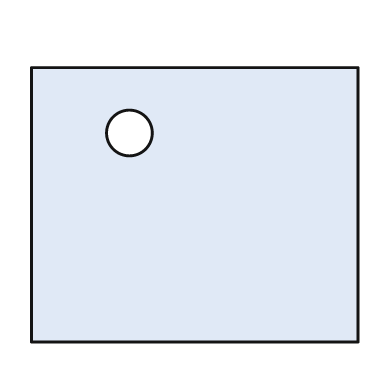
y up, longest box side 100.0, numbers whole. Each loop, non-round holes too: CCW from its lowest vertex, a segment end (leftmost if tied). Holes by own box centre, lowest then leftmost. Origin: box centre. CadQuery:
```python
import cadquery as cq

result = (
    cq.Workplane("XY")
    .moveTo(-50.0, -42.0)
    .lineTo(50.0, -42.0)
    .lineTo(50.0, 42.0)
    .lineTo(-50.0, 42.0)
    .close()
    .moveTo(-20.0, 22.0)
    .circle(7.0)
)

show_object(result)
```